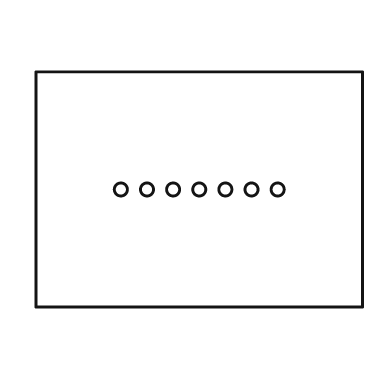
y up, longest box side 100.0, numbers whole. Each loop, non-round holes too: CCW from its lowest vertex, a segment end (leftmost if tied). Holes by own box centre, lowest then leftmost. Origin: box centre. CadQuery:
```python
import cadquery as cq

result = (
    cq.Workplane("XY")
    .moveTo(-50.0, -36.0)
    .lineTo(50.0, -36.0)
    .lineTo(50.0, 36.0)
    .lineTo(-50.0, 36.0)
    .close()
    .moveTo(-24.0, 0.0)
    .circle(2.0)
    .moveTo(-16.0, 0.0)
    .circle(2.0)
    .moveTo(-8.0, 0.0)
    .circle(2.0)
    .moveTo(0.0, 0.0)
    .circle(2.0)
    .moveTo(8.0, 0.0)
    .circle(2.0)
    .moveTo(16.0, 0.0)
    .circle(2.0)
    .moveTo(24.0, 0.0)
    .circle(2.0)
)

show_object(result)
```